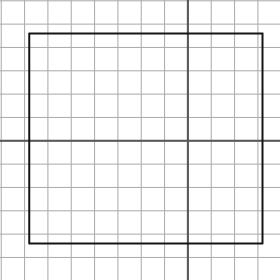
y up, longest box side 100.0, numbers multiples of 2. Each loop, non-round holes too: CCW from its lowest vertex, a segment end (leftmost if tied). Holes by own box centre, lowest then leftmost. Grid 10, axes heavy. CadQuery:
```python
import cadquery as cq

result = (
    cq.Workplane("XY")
    .moveTo(-68.0, -44.0)
    .lineTo(32.0, -44.0)
    .lineTo(32.0, 46.0)
    .lineTo(-68.0, 46.0)
    .close()
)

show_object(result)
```